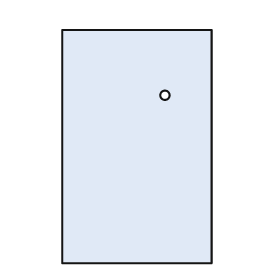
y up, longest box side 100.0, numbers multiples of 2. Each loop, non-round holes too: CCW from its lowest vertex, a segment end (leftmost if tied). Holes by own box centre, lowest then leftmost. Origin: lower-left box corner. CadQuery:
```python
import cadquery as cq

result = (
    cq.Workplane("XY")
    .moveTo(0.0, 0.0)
    .lineTo(64.0, 0.0)
    .lineTo(64.0, 100.0)
    .lineTo(0.0, 100.0)
    .close()
    .moveTo(44.0, 72.0)
    .circle(2.0)
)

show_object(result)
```